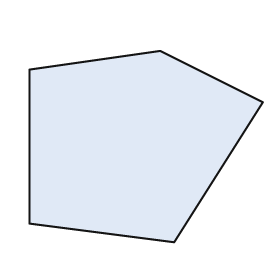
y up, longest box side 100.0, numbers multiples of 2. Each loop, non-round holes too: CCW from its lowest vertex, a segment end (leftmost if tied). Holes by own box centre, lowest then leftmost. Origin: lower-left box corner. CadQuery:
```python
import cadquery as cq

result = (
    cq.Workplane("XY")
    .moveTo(62.0, 0.0)
    .lineTo(100.0, 60.0)
    .lineTo(56.0, 82.0)
    .lineTo(0.0, 74.0)
    .lineTo(0.0, 8.0)
    .close()
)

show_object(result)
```